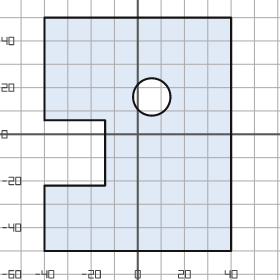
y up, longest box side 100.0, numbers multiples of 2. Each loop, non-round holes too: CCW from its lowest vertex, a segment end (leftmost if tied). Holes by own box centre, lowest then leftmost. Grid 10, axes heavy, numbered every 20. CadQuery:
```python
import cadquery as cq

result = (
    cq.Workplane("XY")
    .moveTo(-40.0, -50.0)
    .lineTo(40.0, -50.0)
    .lineTo(40.0, 50.0)
    .lineTo(-40.0, 50.0)
    .lineTo(-40.0, 6.0)
    .lineTo(-14.0, 6.0)
    .lineTo(-14.0, -22.0)
    .lineTo(-40.0, -22.0)
    .close()
    .moveTo(6.0, 16.0)
    .circle(8.0)
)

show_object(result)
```